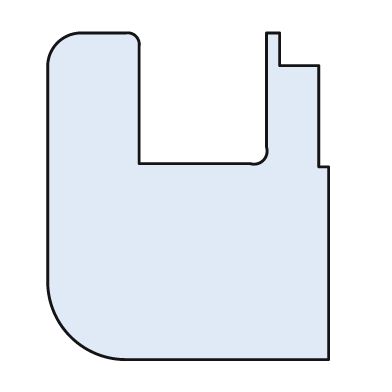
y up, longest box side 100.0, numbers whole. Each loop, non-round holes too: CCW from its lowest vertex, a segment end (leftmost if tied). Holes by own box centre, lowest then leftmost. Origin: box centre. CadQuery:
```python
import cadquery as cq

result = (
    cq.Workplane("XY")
    .moveTo(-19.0, -50.0)
    .lineTo(43.0, -50.0)
    .lineTo(43.0, 9.0)
    .lineTo(40.0, 9.0)
    .lineTo(40.0, 40.0)
    .lineTo(28.0, 40.0)
    .lineTo(28.0, 50.0)
    .lineTo(24.0, 50.0)
    .lineTo(24.0, 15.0)
    .threePointArc((23.0, 11.0), (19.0, 10.0))
    .lineTo(-15.0, 10.0)
    .lineTo(-15.0, 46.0)
    .threePointArc((-16.0, 49.0), (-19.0, 50.0))
    .lineTo(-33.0, 50.0)
    .threePointArc((-40.0, 47.0), (-43.0, 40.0))
    .lineTo(-43.0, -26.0)
    .threePointArc((-36.0, -43.0), (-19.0, -50.0))
    .close()
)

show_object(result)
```